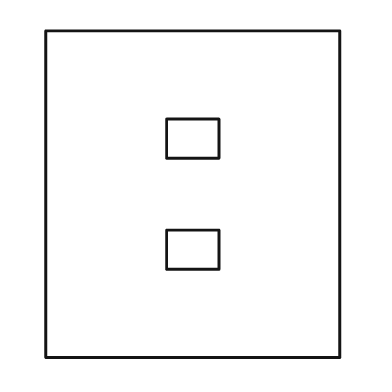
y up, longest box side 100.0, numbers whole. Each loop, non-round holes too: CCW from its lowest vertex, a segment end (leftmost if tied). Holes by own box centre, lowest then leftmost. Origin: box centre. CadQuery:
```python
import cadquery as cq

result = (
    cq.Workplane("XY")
    .moveTo(-45.0, -50.0)
    .lineTo(45.0, -50.0)
    .lineTo(45.0, 50.0)
    .lineTo(-45.0, 50.0)
    .close()
    .moveTo(-8.0, -23.0)
    .lineTo(8.0, -23.0)
    .lineTo(8.0, -11.0)
    .lineTo(-8.0, -11.0)
    .close()
    .moveTo(-8.0, 11.0)
    .lineTo(8.0, 11.0)
    .lineTo(8.0, 23.0)
    .lineTo(-8.0, 23.0)
    .close()
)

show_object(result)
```